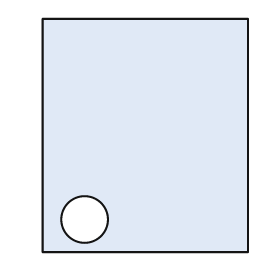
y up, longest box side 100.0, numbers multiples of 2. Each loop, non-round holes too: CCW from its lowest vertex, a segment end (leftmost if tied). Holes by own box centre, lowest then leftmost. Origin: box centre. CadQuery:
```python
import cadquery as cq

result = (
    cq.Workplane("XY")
    .moveTo(-44.0, -50.0)
    .lineTo(44.0, -50.0)
    .lineTo(44.0, 50.0)
    .lineTo(-44.0, 50.0)
    .close()
    .moveTo(-26.0, -36.0)
    .circle(10.0)
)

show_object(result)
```